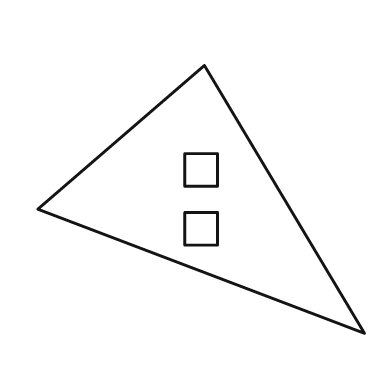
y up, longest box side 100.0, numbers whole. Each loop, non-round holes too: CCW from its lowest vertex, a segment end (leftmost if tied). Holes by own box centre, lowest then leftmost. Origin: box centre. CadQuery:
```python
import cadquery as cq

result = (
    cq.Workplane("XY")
    .moveTo(50.0, -41.0)
    .lineTo(1.0, 41.0)
    .lineTo(-50.0, -3.0)
    .close()
    .moveTo(-5.0, -14.0)
    .lineTo(5.0, -14.0)
    .lineTo(5.0, -4.0)
    .lineTo(-5.0, -4.0)
    .close()
    .moveTo(-5.0, 4.0)
    .lineTo(5.0, 4.0)
    .lineTo(5.0, 14.0)
    .lineTo(-5.0, 14.0)
    .close()
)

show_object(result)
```